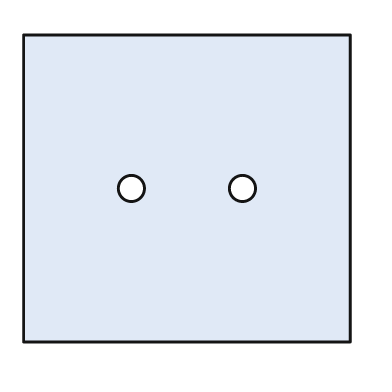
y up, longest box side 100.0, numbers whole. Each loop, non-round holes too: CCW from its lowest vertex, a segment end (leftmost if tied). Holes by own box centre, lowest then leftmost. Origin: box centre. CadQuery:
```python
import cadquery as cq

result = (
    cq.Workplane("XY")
    .moveTo(-50.0, -47.0)
    .lineTo(50.0, -47.0)
    .lineTo(50.0, 47.0)
    .lineTo(-50.0, 47.0)
    .close()
    .moveTo(-17.0, 0.0)
    .circle(4.0)
    .moveTo(17.0, 0.0)
    .circle(4.0)
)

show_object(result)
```